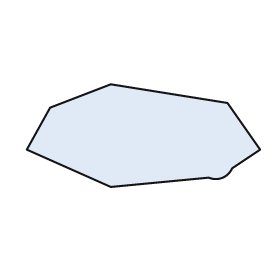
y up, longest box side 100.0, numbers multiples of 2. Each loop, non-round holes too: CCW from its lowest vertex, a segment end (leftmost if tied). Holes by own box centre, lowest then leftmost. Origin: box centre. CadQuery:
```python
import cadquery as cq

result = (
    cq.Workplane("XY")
    .moveTo(-14.0, -22.0)
    .lineTo(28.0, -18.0)
    .threePointArc((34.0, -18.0), (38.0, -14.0))
    .lineTo(50.0, -6.0)
    .lineTo(36.0, 14.0)
    .lineTo(-14.0, 22.0)
    .lineTo(-40.0, 12.0)
    .lineTo(-50.0, -6.0)
    .close()
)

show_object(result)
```